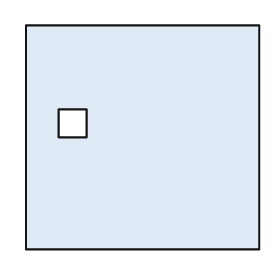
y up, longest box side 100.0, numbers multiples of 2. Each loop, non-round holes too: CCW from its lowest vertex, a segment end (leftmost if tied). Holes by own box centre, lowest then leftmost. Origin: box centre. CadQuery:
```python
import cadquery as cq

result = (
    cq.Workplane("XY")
    .moveTo(-50.0, -48.0)
    .lineTo(50.0, -48.0)
    .lineTo(50.0, 48.0)
    .lineTo(-50.0, 48.0)
    .close()
    .moveTo(-36.0, 0.0)
    .lineTo(-24.0, 0.0)
    .lineTo(-24.0, 12.0)
    .lineTo(-36.0, 12.0)
    .close()
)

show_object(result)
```